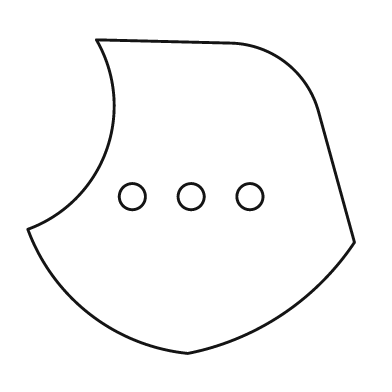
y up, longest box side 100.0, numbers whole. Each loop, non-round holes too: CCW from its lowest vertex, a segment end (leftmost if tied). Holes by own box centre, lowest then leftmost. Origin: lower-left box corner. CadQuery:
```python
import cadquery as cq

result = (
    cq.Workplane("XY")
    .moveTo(49.0, 0.0)
    .threePointArc((78.0, 12.0), (100.0, 34.0))
    .lineTo(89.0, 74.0)
    .threePointArc((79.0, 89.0), (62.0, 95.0))
    .lineTo(21.0, 96.0)
    .threePointArc((24.0, 62.0), (0.0, 38.0))
    .threePointArc((19.0, 12.0), (49.0, 0.0))
    .close()
    .moveTo(32.0, 48.0)
    .circle(4.0)
    .moveTo(50.0, 48.0)
    .circle(4.0)
    .moveTo(68.0, 48.0)
    .circle(4.0)
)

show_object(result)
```